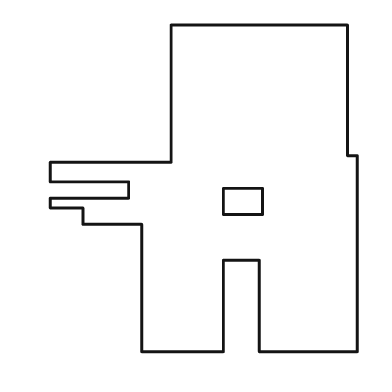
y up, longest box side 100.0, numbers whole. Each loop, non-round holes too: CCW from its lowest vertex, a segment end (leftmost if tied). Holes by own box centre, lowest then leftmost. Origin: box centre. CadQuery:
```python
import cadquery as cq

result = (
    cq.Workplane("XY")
    .moveTo(-19.0, -50.0)
    .lineTo(6.0, -50.0)
    .lineTo(6.0, -22.0)
    .lineTo(17.0, -22.0)
    .lineTo(17.0, -50.0)
    .lineTo(47.0, -50.0)
    .lineTo(47.0, 10.0)
    .lineTo(44.0, 10.0)
    .lineTo(44.0, 50.0)
    .lineTo(-10.0, 50.0)
    .lineTo(-10.0, 8.0)
    .lineTo(-47.0, 8.0)
    .lineTo(-47.0, 2.0)
    .lineTo(-23.0, 2.0)
    .lineTo(-23.0, -3.0)
    .lineTo(-47.0, -3.0)
    .lineTo(-47.0, -6.0)
    .lineTo(-37.0, -6.0)
    .lineTo(-37.0, -11.0)
    .lineTo(-19.0, -11.0)
    .close()
    .moveTo(6.0, -8.0)
    .lineTo(18.0, -8.0)
    .lineTo(18.0, 0.0)
    .lineTo(6.0, 0.0)
    .close()
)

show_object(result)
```